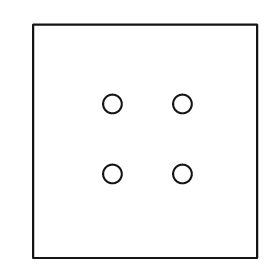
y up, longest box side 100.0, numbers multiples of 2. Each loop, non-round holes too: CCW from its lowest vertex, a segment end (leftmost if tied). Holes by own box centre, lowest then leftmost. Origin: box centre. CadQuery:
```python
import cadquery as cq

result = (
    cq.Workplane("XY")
    .moveTo(-48.0, -50.0)
    .lineTo(48.0, -50.0)
    .lineTo(48.0, 50.0)
    .lineTo(-48.0, 50.0)
    .close()
    .moveTo(-14.0, -14.0)
    .circle(4.0)
    .moveTo(16.0, -14.0)
    .circle(4.0)
    .moveTo(-14.0, 16.0)
    .circle(4.0)
    .moveTo(16.0, 16.0)
    .circle(4.0)
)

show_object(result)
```